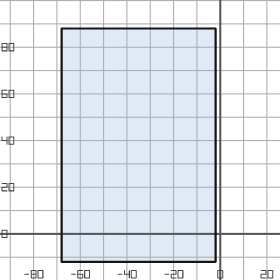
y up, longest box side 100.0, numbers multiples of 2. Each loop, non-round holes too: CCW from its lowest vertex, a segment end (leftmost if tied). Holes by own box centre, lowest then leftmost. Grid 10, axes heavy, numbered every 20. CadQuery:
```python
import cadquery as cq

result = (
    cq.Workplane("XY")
    .moveTo(-68.0, -12.0)
    .lineTo(-2.0, -12.0)
    .lineTo(-2.0, 88.0)
    .lineTo(-68.0, 88.0)
    .close()
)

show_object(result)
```